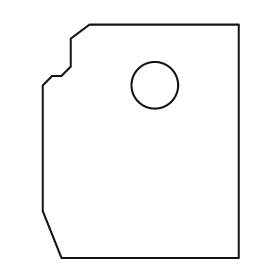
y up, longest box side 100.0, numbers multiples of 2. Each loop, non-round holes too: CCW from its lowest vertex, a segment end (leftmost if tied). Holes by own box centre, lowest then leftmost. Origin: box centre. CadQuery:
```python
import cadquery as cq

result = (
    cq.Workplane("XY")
    .moveTo(-34.0, -50.0)
    .lineTo(42.0, -50.0)
    .lineTo(42.0, 50.0)
    .lineTo(-22.0, 50.0)
    .lineTo(-30.0, 44.0)
    .lineTo(-30.0, 32.0)
    .lineTo(-34.0, 28.0)
    .lineTo(-38.0, 28.0)
    .lineTo(-42.0, 24.0)
    .lineTo(-42.0, -30.0)
    .close()
    .moveTo(6.0, 24.0)
    .circle(10.0)
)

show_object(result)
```